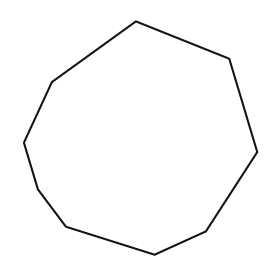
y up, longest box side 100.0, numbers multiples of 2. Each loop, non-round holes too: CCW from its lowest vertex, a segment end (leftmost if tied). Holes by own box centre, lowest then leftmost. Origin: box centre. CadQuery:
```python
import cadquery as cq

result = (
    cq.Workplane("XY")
    .moveTo(6.0, -50.0)
    .lineTo(28.0, -40.0)
    .lineTo(50.0, -6.0)
    .lineTo(38.0, 34.0)
    .lineTo(-2.0, 50.0)
    .lineTo(-38.0, 24.0)
    .lineTo(-50.0, -2.0)
    .lineTo(-44.0, -22.0)
    .lineTo(-32.0, -38.0)
    .close()
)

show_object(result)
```